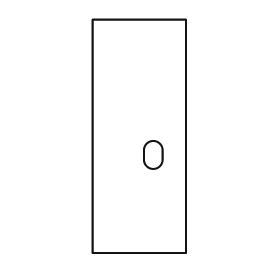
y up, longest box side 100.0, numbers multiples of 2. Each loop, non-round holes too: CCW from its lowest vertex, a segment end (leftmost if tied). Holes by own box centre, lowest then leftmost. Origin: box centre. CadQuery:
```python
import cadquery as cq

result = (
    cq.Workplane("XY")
    .moveTo(-20.0, -50.0)
    .lineTo(20.0, -50.0)
    .lineTo(20.0, 50.0)
    .lineTo(-20.0, 50.0)
    .close()
    .moveTo(2.0, -10.0)
    .threePointArc((6.0, -14.0), (10.0, -10.0))
    .lineTo(10.0, -6.0)
    .threePointArc((6.0, -2.0), (2.0, -6.0))
    .close()
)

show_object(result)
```